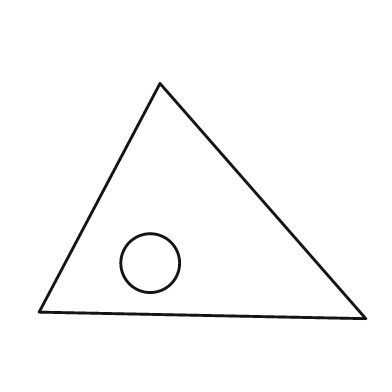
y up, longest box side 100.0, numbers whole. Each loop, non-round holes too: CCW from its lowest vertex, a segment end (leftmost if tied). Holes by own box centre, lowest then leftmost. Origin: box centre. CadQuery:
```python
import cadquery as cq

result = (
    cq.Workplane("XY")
    .moveTo(50.0, -36.0)
    .lineTo(-13.0, 36.0)
    .lineTo(-50.0, -34.0)
    .close()
    .moveTo(-16.0, -19.0)
    .circle(9.0)
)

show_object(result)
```